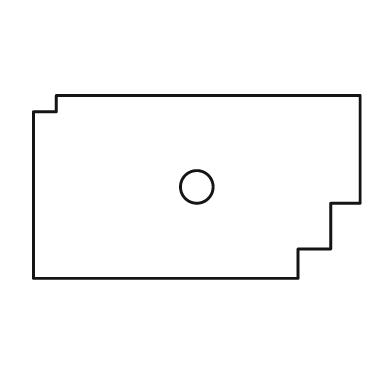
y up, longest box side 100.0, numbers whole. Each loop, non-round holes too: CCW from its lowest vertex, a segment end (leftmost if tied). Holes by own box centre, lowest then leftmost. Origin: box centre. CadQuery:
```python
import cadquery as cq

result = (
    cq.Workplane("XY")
    .moveTo(-50.0, -28.0)
    .lineTo(31.0, -28.0)
    .lineTo(31.0, -19.0)
    .lineTo(41.0, -19.0)
    .lineTo(41.0, -5.0)
    .lineTo(50.0, -5.0)
    .lineTo(50.0, 28.0)
    .lineTo(-43.0, 28.0)
    .lineTo(-43.0, 23.0)
    .lineTo(-50.0, 23.0)
    .close()
    .moveTo(0.0, 0.0)
    .circle(5.0)
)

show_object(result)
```